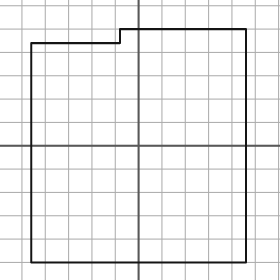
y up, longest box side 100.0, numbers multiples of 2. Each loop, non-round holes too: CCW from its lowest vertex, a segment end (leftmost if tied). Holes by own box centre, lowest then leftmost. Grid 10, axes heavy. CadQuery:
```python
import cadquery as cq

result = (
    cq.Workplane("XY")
    .moveTo(-46.0, -50.0)
    .lineTo(46.0, -50.0)
    .lineTo(46.0, 50.0)
    .lineTo(-8.0, 50.0)
    .lineTo(-8.0, 44.0)
    .lineTo(-46.0, 44.0)
    .close()
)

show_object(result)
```